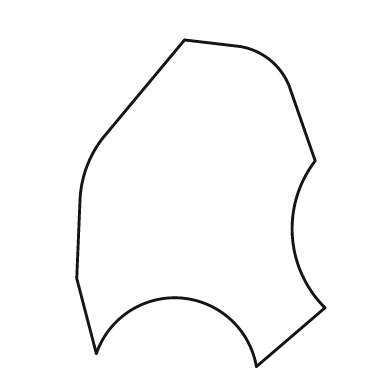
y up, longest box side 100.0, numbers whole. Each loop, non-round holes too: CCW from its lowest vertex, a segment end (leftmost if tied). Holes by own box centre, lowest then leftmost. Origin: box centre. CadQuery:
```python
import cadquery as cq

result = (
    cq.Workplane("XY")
    .moveTo(17.0, -50.0)
    .lineTo(38.0, -32.0)
    .threePointArc((28.0, -10.0), (35.0, 13.0))
    .lineTo(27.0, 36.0)
    .threePointArc((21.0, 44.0), (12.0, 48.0))
    .lineTo(-5.0, 50.0)
    .lineTo(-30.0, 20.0)
    .threePointArc((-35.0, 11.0), (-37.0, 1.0))
    .lineTo(-38.0, -23.0)
    .lineTo(-32.0, -46.0)
    .threePointArc((-6.0, -29.0), (17.0, -50.0))
    .close()
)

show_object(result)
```